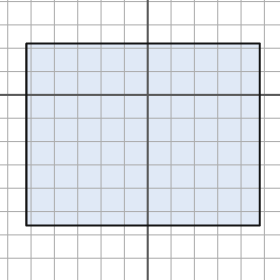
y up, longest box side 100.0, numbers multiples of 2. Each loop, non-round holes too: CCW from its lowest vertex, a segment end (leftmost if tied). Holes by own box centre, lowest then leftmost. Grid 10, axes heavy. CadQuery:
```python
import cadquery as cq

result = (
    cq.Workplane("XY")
    .moveTo(-52.0, -56.0)
    .lineTo(48.0, -56.0)
    .lineTo(48.0, 22.0)
    .lineTo(-52.0, 22.0)
    .close()
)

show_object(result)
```